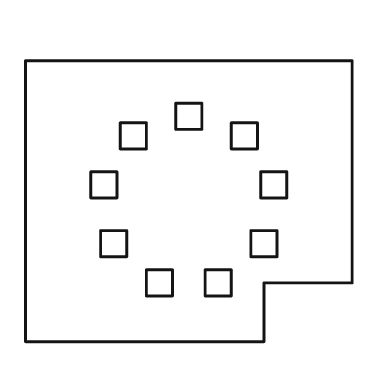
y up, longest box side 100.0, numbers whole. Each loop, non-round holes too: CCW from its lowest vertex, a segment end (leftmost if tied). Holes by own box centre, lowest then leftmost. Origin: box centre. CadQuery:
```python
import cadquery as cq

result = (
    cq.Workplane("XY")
    .moveTo(-50.0, -43.0)
    .lineTo(23.0, -43.0)
    .lineTo(23.0, -25.0)
    .lineTo(50.0, -25.0)
    .lineTo(50.0, 43.0)
    .lineTo(-50.0, 43.0)
    .close()
    .moveTo(-13.0, -29.0)
    .lineTo(-5.0, -29.0)
    .lineTo(-5.0, -21.0)
    .lineTo(-13.0, -21.0)
    .close()
    .moveTo(5.0, -29.0)
    .lineTo(13.0, -29.0)
    .lineTo(13.0, -21.0)
    .lineTo(5.0, -21.0)
    .close()
    .moveTo(-27.0, -17.0)
    .lineTo(-19.0, -17.0)
    .lineTo(-19.0, -9.0)
    .lineTo(-27.0, -9.0)
    .close()
    .moveTo(19.0, -17.0)
    .lineTo(27.0, -17.0)
    .lineTo(27.0, -9.0)
    .lineTo(19.0, -9.0)
    .close()
    .moveTo(-30.0, 1.0)
    .lineTo(-22.0, 1.0)
    .lineTo(-22.0, 9.0)
    .lineTo(-30.0, 9.0)
    .close()
    .moveTo(22.0, 1.0)
    .lineTo(30.0, 1.0)
    .lineTo(30.0, 9.0)
    .lineTo(22.0, 9.0)
    .close()
    .moveTo(-21.0, 16.0)
    .lineTo(-13.0, 16.0)
    .lineTo(-13.0, 24.0)
    .lineTo(-21.0, 24.0)
    .close()
    .moveTo(13.0, 16.0)
    .lineTo(21.0, 16.0)
    .lineTo(21.0, 24.0)
    .lineTo(13.0, 24.0)
    .close()
    .moveTo(-4.0, 22.0)
    .lineTo(4.0, 22.0)
    .lineTo(4.0, 30.0)
    .lineTo(-4.0, 30.0)
    .close()
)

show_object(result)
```